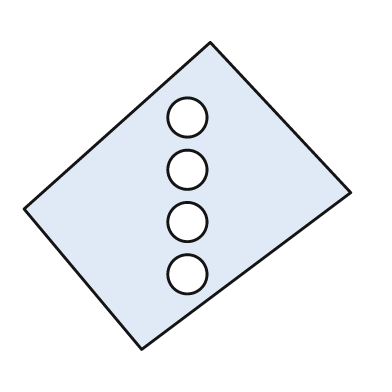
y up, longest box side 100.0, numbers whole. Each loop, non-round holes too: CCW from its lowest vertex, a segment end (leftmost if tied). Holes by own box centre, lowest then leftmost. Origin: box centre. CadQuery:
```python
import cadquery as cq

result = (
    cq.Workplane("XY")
    .moveTo(-14.0, -47.0)
    .lineTo(50.0, 1.0)
    .lineTo(7.0, 47.0)
    .lineTo(-50.0, -4.0)
    .close()
    .moveTo(0.0, -24.0)
    .circle(6.0)
    .moveTo(0.0, -8.0)
    .circle(6.0)
    .moveTo(0.0, 8.0)
    .circle(6.0)
    .moveTo(0.0, 24.0)
    .circle(6.0)
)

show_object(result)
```